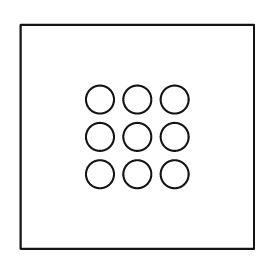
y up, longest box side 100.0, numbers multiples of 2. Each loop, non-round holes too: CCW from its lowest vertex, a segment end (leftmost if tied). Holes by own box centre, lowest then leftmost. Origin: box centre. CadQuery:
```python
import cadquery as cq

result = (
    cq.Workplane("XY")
    .moveTo(-50.0, -48.0)
    .lineTo(50.0, -48.0)
    .lineTo(50.0, 48.0)
    .lineTo(-50.0, 48.0)
    .close()
    .moveTo(-16.0, -16.0)
    .circle(6.0)
    .moveTo(0.0, -16.0)
    .circle(6.0)
    .moveTo(16.0, -16.0)
    .circle(6.0)
    .moveTo(-16.0, 0.0)
    .circle(6.0)
    .moveTo(0.0, 0.0)
    .circle(6.0)
    .moveTo(16.0, 0.0)
    .circle(6.0)
    .moveTo(-16.0, 16.0)
    .circle(6.0)
    .moveTo(0.0, 16.0)
    .circle(6.0)
    .moveTo(16.0, 16.0)
    .circle(6.0)
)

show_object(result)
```